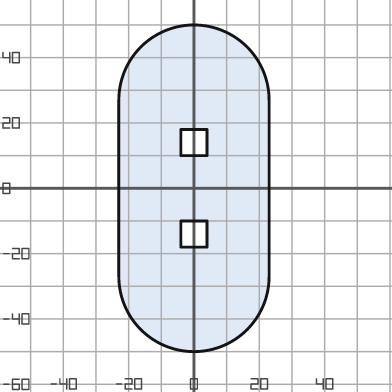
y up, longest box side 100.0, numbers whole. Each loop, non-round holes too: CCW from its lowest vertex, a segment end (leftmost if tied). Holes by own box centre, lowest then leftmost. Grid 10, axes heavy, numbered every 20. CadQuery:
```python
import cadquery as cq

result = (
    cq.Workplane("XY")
    .moveTo(-23.0, -27.0)
    .threePointArc((0.0, -50.0), (23.0, -27.0))
    .lineTo(23.0, 27.0)
    .threePointArc((0.0, 50.0), (-23.0, 27.0))
    .close()
    .moveTo(-4.0, -18.0)
    .lineTo(4.0, -18.0)
    .lineTo(4.0, -10.0)
    .lineTo(-4.0, -10.0)
    .close()
    .moveTo(-4.0, 10.0)
    .lineTo(4.0, 10.0)
    .lineTo(4.0, 18.0)
    .lineTo(-4.0, 18.0)
    .close()
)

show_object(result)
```